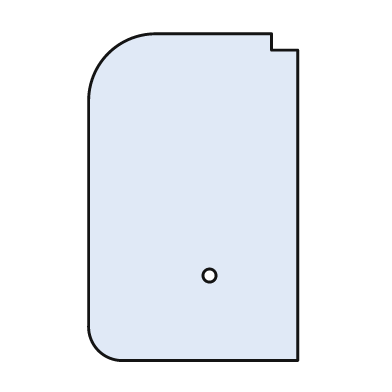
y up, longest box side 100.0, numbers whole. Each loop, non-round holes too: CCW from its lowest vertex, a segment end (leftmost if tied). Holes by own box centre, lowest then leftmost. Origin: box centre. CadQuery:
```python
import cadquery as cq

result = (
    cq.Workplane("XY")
    .moveTo(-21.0, -50.0)
    .lineTo(32.0, -50.0)
    .lineTo(32.0, 45.0)
    .lineTo(24.0, 45.0)
    .lineTo(24.0, 50.0)
    .lineTo(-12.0, 50.0)
    .threePointArc((-26.0, 44.0), (-32.0, 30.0))
    .lineTo(-32.0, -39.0)
    .threePointArc((-29.0, -47.0), (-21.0, -50.0))
    .close()
    .moveTo(5.0, -24.0)
    .circle(2.0)
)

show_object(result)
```